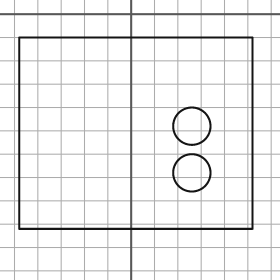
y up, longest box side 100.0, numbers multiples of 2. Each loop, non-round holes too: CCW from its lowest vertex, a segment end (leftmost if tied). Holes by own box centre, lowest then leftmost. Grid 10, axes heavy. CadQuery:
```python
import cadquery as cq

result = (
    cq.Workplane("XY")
    .moveTo(-48.0, -92.0)
    .lineTo(52.0, -92.0)
    .lineTo(52.0, -10.0)
    .lineTo(-48.0, -10.0)
    .close()
    .moveTo(26.0, -68.0)
    .circle(8.0)
    .moveTo(26.0, -48.0)
    .circle(8.0)
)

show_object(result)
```